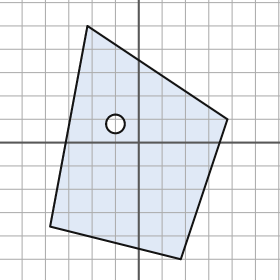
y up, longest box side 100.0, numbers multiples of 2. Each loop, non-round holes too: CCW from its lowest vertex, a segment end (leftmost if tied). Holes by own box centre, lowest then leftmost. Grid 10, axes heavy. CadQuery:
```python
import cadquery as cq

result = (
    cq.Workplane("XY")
    .moveTo(18.0, -50.0)
    .lineTo(38.0, 10.0)
    .lineTo(-22.0, 50.0)
    .lineTo(-38.0, -36.0)
    .close()
    .moveTo(-10.0, 8.0)
    .circle(4.0)
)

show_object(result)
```